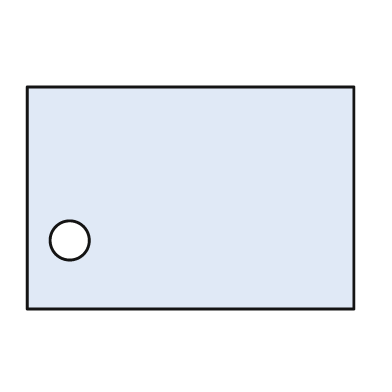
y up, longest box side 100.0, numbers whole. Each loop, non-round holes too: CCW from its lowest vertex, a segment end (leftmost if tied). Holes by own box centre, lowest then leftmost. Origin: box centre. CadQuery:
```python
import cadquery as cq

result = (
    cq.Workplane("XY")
    .moveTo(-50.0, -34.0)
    .lineTo(50.0, -34.0)
    .lineTo(50.0, 34.0)
    .lineTo(-50.0, 34.0)
    .close()
    .moveTo(-37.0, -13.0)
    .circle(6.0)
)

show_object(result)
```